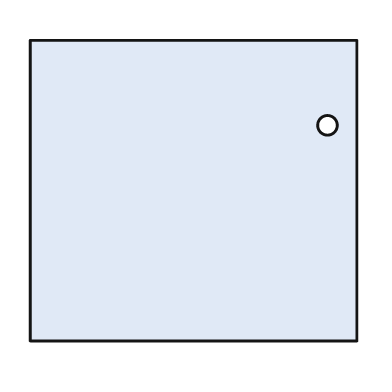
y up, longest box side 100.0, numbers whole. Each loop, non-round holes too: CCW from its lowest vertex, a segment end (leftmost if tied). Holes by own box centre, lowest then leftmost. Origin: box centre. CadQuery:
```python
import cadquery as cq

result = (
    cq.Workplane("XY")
    .moveTo(-50.0, -46.0)
    .lineTo(50.0, -46.0)
    .lineTo(50.0, 46.0)
    .lineTo(-50.0, 46.0)
    .close()
    .moveTo(41.0, 20.0)
    .circle(3.0)
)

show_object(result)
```